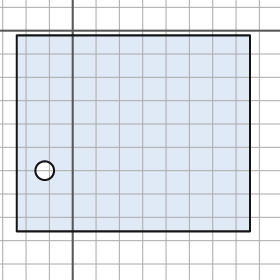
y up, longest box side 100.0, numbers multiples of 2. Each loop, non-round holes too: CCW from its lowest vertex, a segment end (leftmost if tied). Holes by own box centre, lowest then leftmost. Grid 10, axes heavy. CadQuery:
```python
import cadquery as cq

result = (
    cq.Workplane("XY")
    .moveTo(-24.0, -86.0)
    .lineTo(76.0, -86.0)
    .lineTo(76.0, -2.0)
    .lineTo(-24.0, -2.0)
    .close()
    .moveTo(-12.0, -60.0)
    .circle(4.0)
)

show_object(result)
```